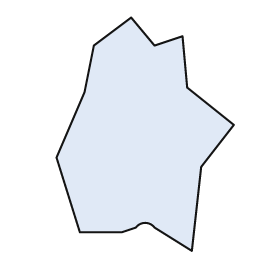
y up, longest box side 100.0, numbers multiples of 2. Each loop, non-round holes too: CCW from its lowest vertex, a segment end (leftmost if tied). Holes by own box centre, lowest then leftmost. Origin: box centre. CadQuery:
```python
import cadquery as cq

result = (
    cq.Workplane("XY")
    .moveTo(20.0, -50.0)
    .lineTo(24.0, -14.0)
    .lineTo(38.0, 4.0)
    .lineTo(18.0, 20.0)
    .lineTo(16.0, 42.0)
    .lineTo(4.0, 38.0)
    .lineTo(-6.0, 50.0)
    .lineTo(-22.0, 38.0)
    .lineTo(-26.0, 18.0)
    .lineTo(-38.0, -10.0)
    .lineTo(-28.0, -42.0)
    .lineTo(-10.0, -42.0)
    .lineTo(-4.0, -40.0)
    .threePointArc((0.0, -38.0), (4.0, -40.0))
    .close()
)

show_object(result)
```